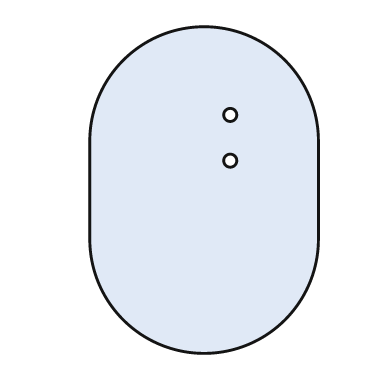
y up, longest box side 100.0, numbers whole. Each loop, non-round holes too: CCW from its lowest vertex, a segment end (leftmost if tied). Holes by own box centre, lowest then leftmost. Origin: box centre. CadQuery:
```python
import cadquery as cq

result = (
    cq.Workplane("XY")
    .moveTo(-35.0, -15.0)
    .threePointArc((0.0, -50.0), (35.0, -15.0))
    .lineTo(35.0, 15.0)
    .threePointArc((0.0, 50.0), (-35.0, 15.0))
    .close()
    .moveTo(8.0, 9.0)
    .circle(2.0)
    .moveTo(8.0, 23.0)
    .circle(2.0)
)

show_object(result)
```